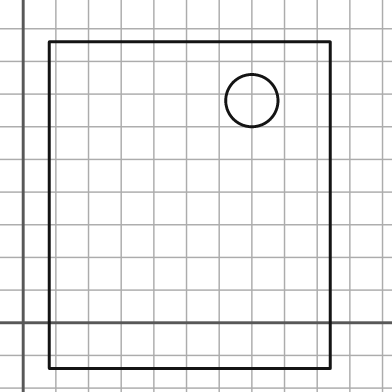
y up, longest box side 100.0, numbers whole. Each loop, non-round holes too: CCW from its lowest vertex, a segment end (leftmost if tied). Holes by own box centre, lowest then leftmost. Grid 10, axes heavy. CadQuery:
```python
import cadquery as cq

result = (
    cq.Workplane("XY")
    .moveTo(8.0, -14.0)
    .lineTo(94.0, -14.0)
    .lineTo(94.0, 86.0)
    .lineTo(8.0, 86.0)
    .close()
    .moveTo(70.0, 68.0)
    .circle(8.0)
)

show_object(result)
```